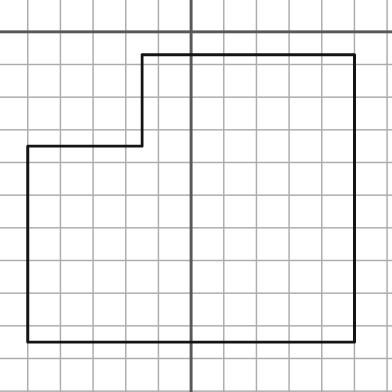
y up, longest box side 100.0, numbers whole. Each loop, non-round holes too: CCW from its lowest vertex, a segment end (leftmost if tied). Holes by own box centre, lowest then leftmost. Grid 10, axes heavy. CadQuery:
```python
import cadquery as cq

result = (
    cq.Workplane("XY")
    .moveTo(-50.0, -95.0)
    .lineTo(50.0, -95.0)
    .lineTo(50.0, -7.0)
    .lineTo(-15.0, -7.0)
    .lineTo(-15.0, -35.0)
    .lineTo(-50.0, -35.0)
    .close()
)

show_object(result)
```